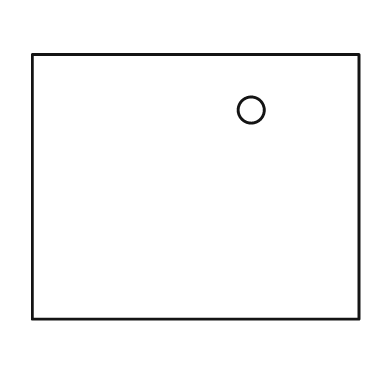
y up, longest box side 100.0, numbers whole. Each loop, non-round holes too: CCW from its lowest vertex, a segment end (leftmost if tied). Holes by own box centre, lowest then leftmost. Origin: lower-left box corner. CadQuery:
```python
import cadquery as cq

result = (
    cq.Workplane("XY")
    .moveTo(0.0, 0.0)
    .lineTo(100.0, 0.0)
    .lineTo(100.0, 81.0)
    .lineTo(0.0, 81.0)
    .close()
    .moveTo(67.0, 64.0)
    .circle(4.0)
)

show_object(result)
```